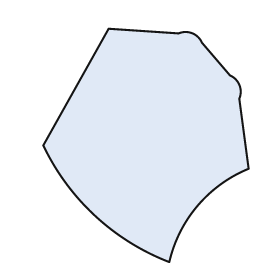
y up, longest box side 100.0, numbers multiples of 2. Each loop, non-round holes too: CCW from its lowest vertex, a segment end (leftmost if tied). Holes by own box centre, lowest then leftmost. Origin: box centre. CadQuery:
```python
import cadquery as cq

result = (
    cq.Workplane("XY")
    .moveTo(10.0, -50.0)
    .threePointArc((22.0, -26.0), (44.0, -10.0))
    .lineTo(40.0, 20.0)
    .threePointArc((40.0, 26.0), (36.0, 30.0))
    .lineTo(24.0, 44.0)
    .threePointArc((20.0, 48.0), (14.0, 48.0))
    .lineTo(-16.0, 50.0)
    .lineTo(-44.0, 0.0)
    .threePointArc((-22.0, -30.0), (10.0, -50.0))
    .close()
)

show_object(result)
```